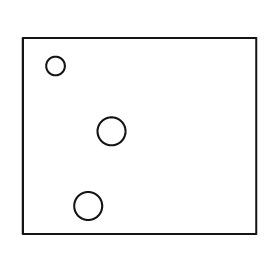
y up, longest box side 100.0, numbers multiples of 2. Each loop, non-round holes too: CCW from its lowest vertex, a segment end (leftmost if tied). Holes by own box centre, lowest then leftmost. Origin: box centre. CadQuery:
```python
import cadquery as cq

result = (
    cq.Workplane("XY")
    .moveTo(-50.0, -42.0)
    .lineTo(50.0, -42.0)
    .lineTo(50.0, 42.0)
    .lineTo(-50.0, 42.0)
    .close()
    .moveTo(-22.0, -30.0)
    .circle(6.0)
    .moveTo(-12.0, 2.0)
    .circle(6.0)
    .moveTo(-36.0, 30.0)
    .circle(4.0)
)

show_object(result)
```